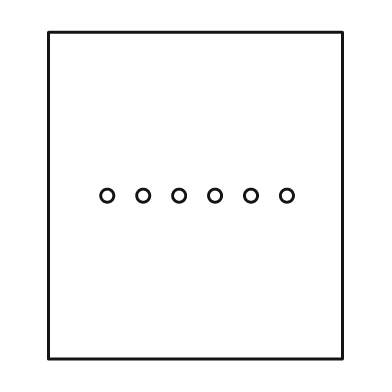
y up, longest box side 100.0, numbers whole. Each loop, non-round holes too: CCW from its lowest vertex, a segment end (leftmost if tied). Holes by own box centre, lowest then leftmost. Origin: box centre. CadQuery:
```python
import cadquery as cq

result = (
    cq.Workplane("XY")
    .moveTo(-45.0, -50.0)
    .lineTo(45.0, -50.0)
    .lineTo(45.0, 50.0)
    .lineTo(-45.0, 50.0)
    .close()
    .moveTo(-27.0, 0.0)
    .circle(2.0)
    .moveTo(-16.0, 0.0)
    .circle(2.0)
    .moveTo(-5.0, 0.0)
    .circle(2.0)
    .moveTo(6.0, 0.0)
    .circle(2.0)
    .moveTo(17.0, 0.0)
    .circle(2.0)
    .moveTo(28.0, 0.0)
    .circle(2.0)
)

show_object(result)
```